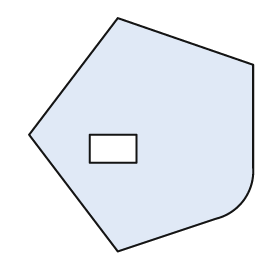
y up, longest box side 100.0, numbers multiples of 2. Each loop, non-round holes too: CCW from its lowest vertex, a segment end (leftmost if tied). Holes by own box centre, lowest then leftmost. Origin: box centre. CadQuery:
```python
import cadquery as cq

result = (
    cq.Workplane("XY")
    .moveTo(-10.0, -50.0)
    .lineTo(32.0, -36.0)
    .threePointArc((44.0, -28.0), (48.0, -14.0))
    .lineTo(48.0, 30.0)
    .lineTo(-10.0, 50.0)
    .lineTo(-48.0, 0.0)
    .close()
    .moveTo(-22.0, -12.0)
    .lineTo(-2.0, -12.0)
    .lineTo(-2.0, 0.0)
    .lineTo(-22.0, 0.0)
    .close()
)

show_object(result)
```